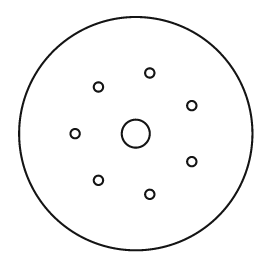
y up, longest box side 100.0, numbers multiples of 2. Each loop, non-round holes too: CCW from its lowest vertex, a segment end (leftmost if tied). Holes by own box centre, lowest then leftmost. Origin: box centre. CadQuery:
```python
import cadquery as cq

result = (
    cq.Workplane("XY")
    .moveTo(0.0, 0.0)
    .circle(50.0)
    .moveTo(6.0, -26.0)
    .circle(2.0)
    .moveTo(-16.0, -20.0)
    .circle(2.0)
    .moveTo(24.0, -12.0)
    .circle(2.0)
    .moveTo(-26.0, 0.0)
    .circle(2.0)
    .moveTo(0.0, 0.0)
    .circle(6.0)
    .moveTo(24.0, 12.0)
    .circle(2.0)
    .moveTo(-16.0, 20.0)
    .circle(2.0)
    .moveTo(6.0, 26.0)
    .circle(2.0)
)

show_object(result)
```